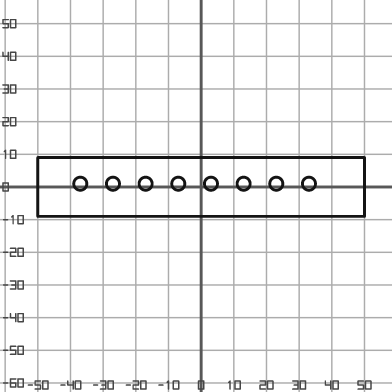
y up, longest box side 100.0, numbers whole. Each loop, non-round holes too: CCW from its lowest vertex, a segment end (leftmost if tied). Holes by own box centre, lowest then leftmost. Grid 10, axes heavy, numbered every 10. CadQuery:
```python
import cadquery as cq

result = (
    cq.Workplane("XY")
    .moveTo(-50.0, -9.0)
    .lineTo(50.0, -9.0)
    .lineTo(50.0, 9.0)
    .lineTo(-50.0, 9.0)
    .close()
    .moveTo(-37.0, 1.0)
    .circle(2.0)
    .moveTo(-27.0, 1.0)
    .circle(2.0)
    .moveTo(-17.0, 1.0)
    .circle(2.0)
    .moveTo(-7.0, 1.0)
    .circle(2.0)
    .moveTo(3.0, 1.0)
    .circle(2.0)
    .moveTo(13.0, 1.0)
    .circle(2.0)
    .moveTo(23.0, 1.0)
    .circle(2.0)
    .moveTo(33.0, 1.0)
    .circle(2.0)
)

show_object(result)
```